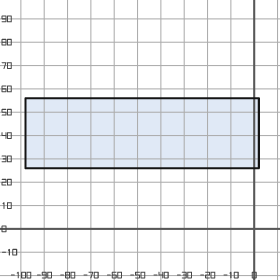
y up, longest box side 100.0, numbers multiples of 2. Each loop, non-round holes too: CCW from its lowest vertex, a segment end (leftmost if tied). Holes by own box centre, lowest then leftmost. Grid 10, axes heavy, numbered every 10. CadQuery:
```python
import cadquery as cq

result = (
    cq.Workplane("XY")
    .moveTo(-98.0, 26.0)
    .lineTo(2.0, 26.0)
    .lineTo(2.0, 56.0)
    .lineTo(-98.0, 56.0)
    .close()
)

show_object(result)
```